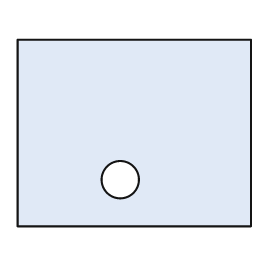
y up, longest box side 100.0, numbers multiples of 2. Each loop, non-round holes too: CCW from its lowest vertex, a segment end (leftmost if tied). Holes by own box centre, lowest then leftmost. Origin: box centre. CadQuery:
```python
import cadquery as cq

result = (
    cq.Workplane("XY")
    .moveTo(-50.0, -40.0)
    .lineTo(50.0, -40.0)
    .lineTo(50.0, 40.0)
    .lineTo(-50.0, 40.0)
    .close()
    .moveTo(-6.0, -20.0)
    .circle(8.0)
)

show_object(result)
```